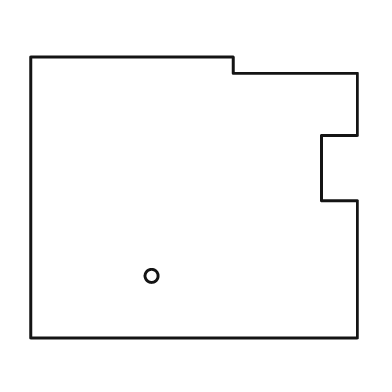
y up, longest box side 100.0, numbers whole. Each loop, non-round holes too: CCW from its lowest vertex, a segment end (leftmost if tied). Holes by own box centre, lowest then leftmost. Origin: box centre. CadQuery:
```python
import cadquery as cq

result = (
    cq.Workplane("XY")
    .moveTo(-50.0, -43.0)
    .lineTo(50.0, -43.0)
    .lineTo(50.0, -1.0)
    .lineTo(39.0, -1.0)
    .lineTo(39.0, 19.0)
    .lineTo(50.0, 19.0)
    .lineTo(50.0, 38.0)
    .lineTo(12.0, 38.0)
    .lineTo(12.0, 43.0)
    .lineTo(-50.0, 43.0)
    .close()
    .moveTo(-13.0, -24.0)
    .circle(2.0)
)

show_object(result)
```